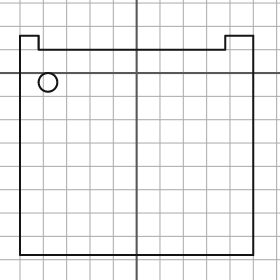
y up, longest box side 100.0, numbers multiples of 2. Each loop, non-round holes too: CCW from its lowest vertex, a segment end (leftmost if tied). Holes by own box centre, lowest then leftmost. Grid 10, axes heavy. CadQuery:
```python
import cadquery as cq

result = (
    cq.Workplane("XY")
    .moveTo(-50.0, -78.0)
    .lineTo(50.0, -78.0)
    .lineTo(50.0, 16.0)
    .lineTo(38.0, 16.0)
    .lineTo(38.0, 10.0)
    .lineTo(-42.0, 10.0)
    .lineTo(-42.0, 16.0)
    .lineTo(-50.0, 16.0)
    .close()
    .moveTo(-38.0, -4.0)
    .circle(4.0)
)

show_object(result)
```